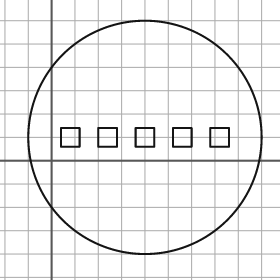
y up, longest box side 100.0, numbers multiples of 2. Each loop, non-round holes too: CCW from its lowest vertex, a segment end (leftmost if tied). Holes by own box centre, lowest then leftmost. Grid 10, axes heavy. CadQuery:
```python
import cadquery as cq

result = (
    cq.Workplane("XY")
    .moveTo(40.0, 10.0)
    .circle(50.0)
    .moveTo(4.0, 6.0)
    .lineTo(12.0, 6.0)
    .lineTo(12.0, 14.0)
    .lineTo(4.0, 14.0)
    .close()
    .moveTo(20.0, 6.0)
    .lineTo(28.0, 6.0)
    .lineTo(28.0, 14.0)
    .lineTo(20.0, 14.0)
    .close()
    .moveTo(36.0, 6.0)
    .lineTo(44.0, 6.0)
    .lineTo(44.0, 14.0)
    .lineTo(36.0, 14.0)
    .close()
    .moveTo(52.0, 6.0)
    .lineTo(60.0, 6.0)
    .lineTo(60.0, 14.0)
    .lineTo(52.0, 14.0)
    .close()
    .moveTo(68.0, 6.0)
    .lineTo(76.0, 6.0)
    .lineTo(76.0, 14.0)
    .lineTo(68.0, 14.0)
    .close()
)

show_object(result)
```